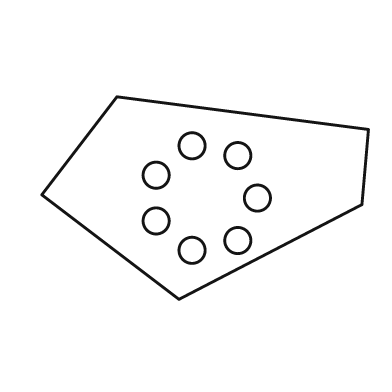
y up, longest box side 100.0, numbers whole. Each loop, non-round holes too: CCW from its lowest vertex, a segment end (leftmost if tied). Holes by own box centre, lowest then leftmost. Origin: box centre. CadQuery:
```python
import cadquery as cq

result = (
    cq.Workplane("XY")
    .moveTo(-8.0, -31.0)
    .lineTo(48.0, -2.0)
    .lineTo(50.0, 21.0)
    .lineTo(-27.0, 31.0)
    .lineTo(-50.0, 1.0)
    .close()
    .moveTo(-4.0, -16.0)
    .circle(4.0)
    .moveTo(10.0, -13.0)
    .circle(4.0)
    .moveTo(-15.0, -7.0)
    .circle(4.0)
    .moveTo(16.0, 0.0)
    .circle(4.0)
    .moveTo(-15.0, 7.0)
    .circle(4.0)
    .moveTo(10.0, 13.0)
    .circle(4.0)
    .moveTo(-4.0, 16.0)
    .circle(4.0)
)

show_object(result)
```